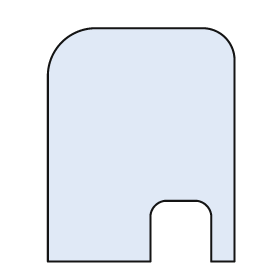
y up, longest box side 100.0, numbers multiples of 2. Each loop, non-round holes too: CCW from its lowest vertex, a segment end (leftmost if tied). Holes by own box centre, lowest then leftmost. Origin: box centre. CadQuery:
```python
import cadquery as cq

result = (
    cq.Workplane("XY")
    .moveTo(-40.0, -50.0)
    .lineTo(4.0, -50.0)
    .lineTo(4.0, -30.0)
    .threePointArc((6.0, -26.0), (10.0, -24.0))
    .lineTo(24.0, -24.0)
    .threePointArc((28.0, -26.0), (30.0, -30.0))
    .lineTo(30.0, -50.0)
    .lineTo(40.0, -50.0)
    .lineTo(40.0, 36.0)
    .threePointArc((36.0, 46.0), (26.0, 50.0))
    .lineTo(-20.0, 50.0)
    .threePointArc((-34.0, 44.0), (-40.0, 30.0))
    .close()
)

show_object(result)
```